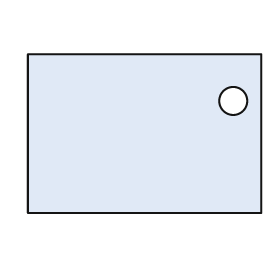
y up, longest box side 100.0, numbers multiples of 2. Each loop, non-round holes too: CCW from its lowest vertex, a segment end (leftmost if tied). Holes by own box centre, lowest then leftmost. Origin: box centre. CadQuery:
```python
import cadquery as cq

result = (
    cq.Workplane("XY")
    .moveTo(-50.0, -34.0)
    .lineTo(50.0, -34.0)
    .lineTo(50.0, 34.0)
    .lineTo(-50.0, 34.0)
    .close()
    .moveTo(38.0, 14.0)
    .circle(6.0)
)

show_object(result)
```